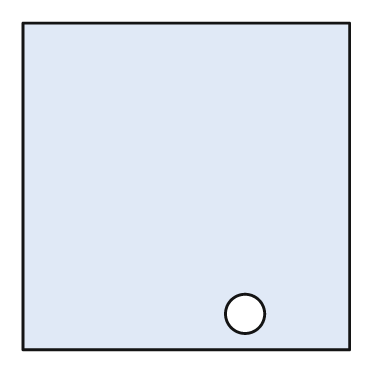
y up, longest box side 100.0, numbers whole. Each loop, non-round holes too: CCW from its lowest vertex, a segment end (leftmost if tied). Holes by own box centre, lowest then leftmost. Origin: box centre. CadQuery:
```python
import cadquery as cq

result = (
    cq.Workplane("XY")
    .moveTo(-50.0, -50.0)
    .lineTo(50.0, -50.0)
    .lineTo(50.0, 50.0)
    .lineTo(-50.0, 50.0)
    .close()
    .moveTo(18.0, -39.0)
    .circle(6.0)
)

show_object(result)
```